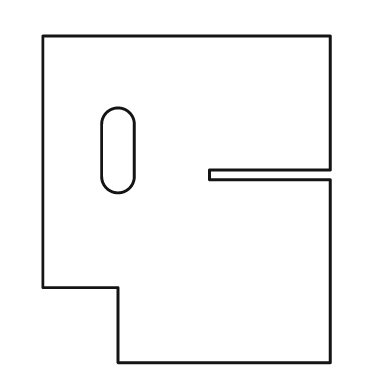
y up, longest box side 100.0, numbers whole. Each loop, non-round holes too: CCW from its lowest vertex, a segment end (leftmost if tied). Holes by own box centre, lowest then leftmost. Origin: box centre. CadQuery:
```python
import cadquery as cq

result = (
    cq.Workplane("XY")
    .moveTo(-21.0, -50.0)
    .lineTo(44.0, -50.0)
    .lineTo(44.0, 6.0)
    .lineTo(7.0, 6.0)
    .lineTo(7.0, 9.0)
    .lineTo(44.0, 9.0)
    .lineTo(44.0, 50.0)
    .lineTo(-44.0, 50.0)
    .lineTo(-44.0, -27.0)
    .lineTo(-21.0, -27.0)
    .close()
    .moveTo(-26.0, 7.0)
    .threePointArc((-21.0, 2.0), (-16.0, 7.0))
    .lineTo(-16.0, 23.0)
    .threePointArc((-21.0, 28.0), (-26.0, 23.0))
    .close()
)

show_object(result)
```